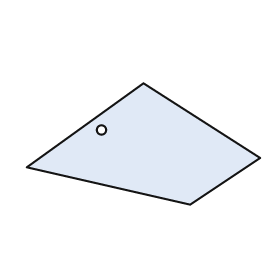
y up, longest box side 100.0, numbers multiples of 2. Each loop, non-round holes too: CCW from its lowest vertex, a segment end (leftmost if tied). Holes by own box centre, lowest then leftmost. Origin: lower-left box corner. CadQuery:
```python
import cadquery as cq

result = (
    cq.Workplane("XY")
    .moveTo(70.0, 0.0)
    .lineTo(100.0, 20.0)
    .lineTo(50.0, 52.0)
    .lineTo(0.0, 16.0)
    .close()
    .moveTo(32.0, 32.0)
    .circle(2.0)
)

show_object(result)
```